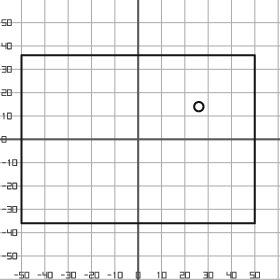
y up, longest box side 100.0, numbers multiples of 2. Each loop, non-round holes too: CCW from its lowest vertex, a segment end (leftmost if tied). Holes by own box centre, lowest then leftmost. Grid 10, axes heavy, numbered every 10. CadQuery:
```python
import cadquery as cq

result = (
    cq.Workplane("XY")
    .moveTo(-50.0, -36.0)
    .lineTo(50.0, -36.0)
    .lineTo(50.0, 36.0)
    .lineTo(-50.0, 36.0)
    .close()
    .moveTo(26.0, 14.0)
    .circle(2.0)
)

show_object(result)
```